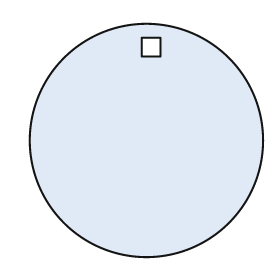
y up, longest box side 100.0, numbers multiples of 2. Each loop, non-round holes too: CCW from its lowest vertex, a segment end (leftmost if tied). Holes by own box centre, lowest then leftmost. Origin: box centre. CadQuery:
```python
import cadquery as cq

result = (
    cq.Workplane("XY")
    .moveTo(0.0, 0.0)
    .circle(50.0)
    .moveTo(-2.0, 36.0)
    .lineTo(6.0, 36.0)
    .lineTo(6.0, 44.0)
    .lineTo(-2.0, 44.0)
    .close()
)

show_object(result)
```